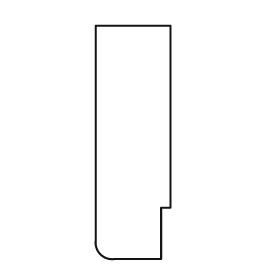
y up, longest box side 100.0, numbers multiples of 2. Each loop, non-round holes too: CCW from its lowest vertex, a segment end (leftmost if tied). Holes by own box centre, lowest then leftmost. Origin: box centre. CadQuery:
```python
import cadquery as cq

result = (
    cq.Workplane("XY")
    .moveTo(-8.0, -50.0)
    .lineTo(12.0, -50.0)
    .lineTo(12.0, -28.0)
    .lineTo(16.0, -28.0)
    .lineTo(16.0, 50.0)
    .lineTo(-16.0, 50.0)
    .lineTo(-16.0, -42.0)
    .threePointArc((-14.0, -48.0), (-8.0, -50.0))
    .close()
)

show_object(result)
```